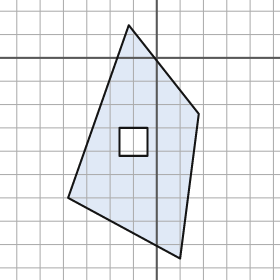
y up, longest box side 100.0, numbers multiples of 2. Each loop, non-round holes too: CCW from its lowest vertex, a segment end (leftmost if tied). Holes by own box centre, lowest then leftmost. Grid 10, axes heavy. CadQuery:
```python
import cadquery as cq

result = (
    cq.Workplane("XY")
    .moveTo(10.0, -86.0)
    .lineTo(18.0, -24.0)
    .lineTo(-12.0, 14.0)
    .lineTo(-38.0, -60.0)
    .close()
    .moveTo(-16.0, -42.0)
    .lineTo(-4.0, -42.0)
    .lineTo(-4.0, -30.0)
    .lineTo(-16.0, -30.0)
    .close()
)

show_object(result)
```